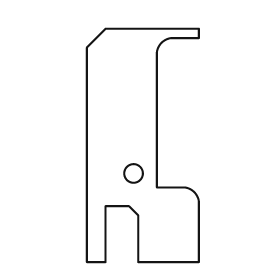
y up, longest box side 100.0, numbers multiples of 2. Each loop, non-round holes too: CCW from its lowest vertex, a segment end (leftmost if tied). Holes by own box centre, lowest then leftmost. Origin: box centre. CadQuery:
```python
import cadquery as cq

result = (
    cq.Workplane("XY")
    .moveTo(-24.0, -50.0)
    .lineTo(-16.0, -50.0)
    .lineTo(-16.0, -26.0)
    .lineTo(-6.0, -26.0)
    .lineTo(-2.0, -30.0)
    .lineTo(-2.0, -50.0)
    .lineTo(24.0, -50.0)
    .lineTo(24.0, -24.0)
    .threePointArc((22.0, -20.0), (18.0, -18.0))
    .lineTo(6.0, -18.0)
    .lineTo(6.0, 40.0)
    .threePointArc((8.0, 44.0), (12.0, 46.0))
    .lineTo(24.0, 46.0)
    .lineTo(24.0, 50.0)
    .lineTo(-16.0, 50.0)
    .lineTo(-24.0, 42.0)
    .close()
    .moveTo(-4.0, -12.0)
    .circle(4.0)
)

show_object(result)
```